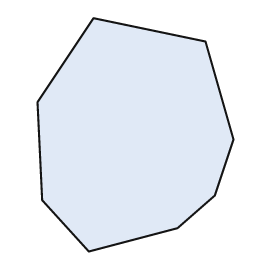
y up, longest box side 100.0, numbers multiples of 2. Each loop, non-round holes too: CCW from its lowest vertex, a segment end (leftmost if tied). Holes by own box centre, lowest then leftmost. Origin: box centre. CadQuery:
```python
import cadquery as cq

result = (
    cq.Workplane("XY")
    .moveTo(-20.0, -50.0)
    .lineTo(18.0, -40.0)
    .lineTo(34.0, -26.0)
    .lineTo(42.0, -2.0)
    .lineTo(30.0, 40.0)
    .lineTo(-18.0, 50.0)
    .lineTo(-42.0, 14.0)
    .lineTo(-40.0, -28.0)
    .close()
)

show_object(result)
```